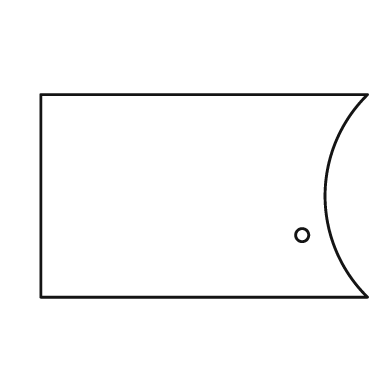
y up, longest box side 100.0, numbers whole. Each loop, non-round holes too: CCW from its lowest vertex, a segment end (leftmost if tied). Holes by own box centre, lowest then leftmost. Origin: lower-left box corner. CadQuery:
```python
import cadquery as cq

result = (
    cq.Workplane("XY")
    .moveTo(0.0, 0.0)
    .lineTo(100.0, 0.0)
    .threePointArc((87.0, 31.0), (100.0, 62.0))
    .lineTo(0.0, 62.0)
    .close()
    .moveTo(80.0, 19.0)
    .circle(2.0)
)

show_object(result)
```